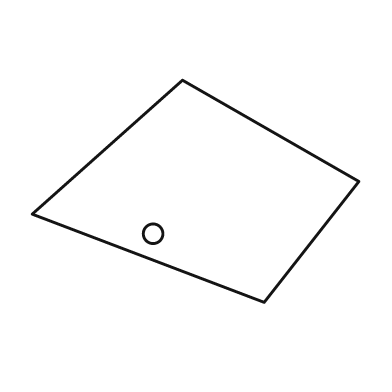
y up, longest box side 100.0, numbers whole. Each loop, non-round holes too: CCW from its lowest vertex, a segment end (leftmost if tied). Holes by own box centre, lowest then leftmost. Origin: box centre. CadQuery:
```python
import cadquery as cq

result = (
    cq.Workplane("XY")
    .moveTo(21.0, -34.0)
    .lineTo(50.0, 3.0)
    .lineTo(-4.0, 34.0)
    .lineTo(-50.0, -7.0)
    .close()
    .moveTo(-13.0, -13.0)
    .circle(3.0)
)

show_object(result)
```